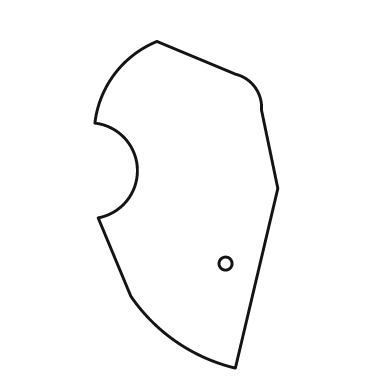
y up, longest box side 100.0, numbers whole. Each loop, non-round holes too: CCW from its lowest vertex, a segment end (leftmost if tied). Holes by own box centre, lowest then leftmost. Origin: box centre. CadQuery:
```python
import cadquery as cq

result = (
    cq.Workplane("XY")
    .moveTo(15.0, -50.0)
    .lineTo(28.0, 5.0)
    .lineTo(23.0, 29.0)
    .threePointArc((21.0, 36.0), (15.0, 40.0))
    .lineTo(-9.0, 50.0)
    .threePointArc((-22.0, 40.0), (-28.0, 25.0))
    .threePointArc((-15.0, 11.0), (-27.0, -4.0))
    .lineTo(-17.0, -28.0)
    .threePointArc((-3.0, -42.0), (15.0, -50.0))
    .close()
    .moveTo(12.0, -18.0)
    .circle(2.0)
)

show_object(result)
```